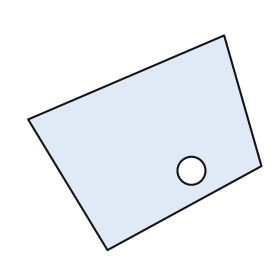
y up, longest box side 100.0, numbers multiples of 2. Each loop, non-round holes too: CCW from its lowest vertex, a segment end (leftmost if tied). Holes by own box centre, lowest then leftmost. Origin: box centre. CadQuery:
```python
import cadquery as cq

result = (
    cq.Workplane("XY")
    .moveTo(-16.0, -46.0)
    .lineTo(50.0, -10.0)
    .lineTo(34.0, 46.0)
    .lineTo(-50.0, 10.0)
    .close()
    .moveTo(20.0, -12.0)
    .circle(6.0)
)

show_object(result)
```